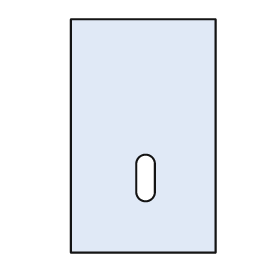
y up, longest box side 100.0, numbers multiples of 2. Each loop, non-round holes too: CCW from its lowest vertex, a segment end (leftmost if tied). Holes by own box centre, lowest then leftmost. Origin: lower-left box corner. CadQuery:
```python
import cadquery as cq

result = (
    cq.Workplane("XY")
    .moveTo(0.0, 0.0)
    .lineTo(62.0, 0.0)
    .lineTo(62.0, 100.0)
    .lineTo(0.0, 100.0)
    .close()
    .moveTo(28.0, 26.0)
    .threePointArc((32.0, 22.0), (36.0, 26.0))
    .lineTo(36.0, 38.0)
    .threePointArc((32.0, 42.0), (28.0, 38.0))
    .close()
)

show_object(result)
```